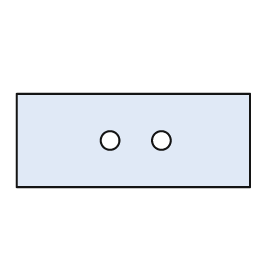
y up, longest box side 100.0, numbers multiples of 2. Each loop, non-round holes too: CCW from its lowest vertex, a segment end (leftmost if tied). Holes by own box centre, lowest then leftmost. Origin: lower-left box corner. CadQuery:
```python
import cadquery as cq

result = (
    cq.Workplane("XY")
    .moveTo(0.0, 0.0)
    .lineTo(100.0, 0.0)
    .lineTo(100.0, 40.0)
    .lineTo(0.0, 40.0)
    .close()
    .moveTo(40.0, 20.0)
    .circle(4.0)
    .moveTo(62.0, 20.0)
    .circle(4.0)
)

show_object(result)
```